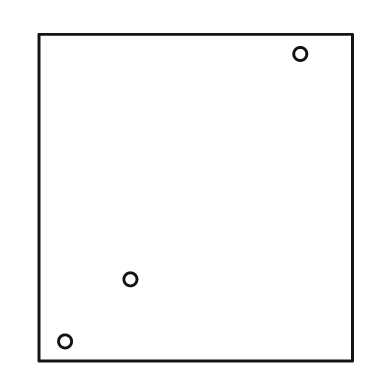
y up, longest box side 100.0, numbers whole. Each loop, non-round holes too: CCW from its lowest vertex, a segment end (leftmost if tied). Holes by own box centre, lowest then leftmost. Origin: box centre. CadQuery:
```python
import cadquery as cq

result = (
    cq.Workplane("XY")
    .moveTo(-48.0, -50.0)
    .lineTo(48.0, -50.0)
    .lineTo(48.0, 50.0)
    .lineTo(-48.0, 50.0)
    .close()
    .moveTo(-40.0, -44.0)
    .circle(2.0)
    .moveTo(-20.0, -25.0)
    .circle(2.0)
    .moveTo(32.0, 44.0)
    .circle(2.0)
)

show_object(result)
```